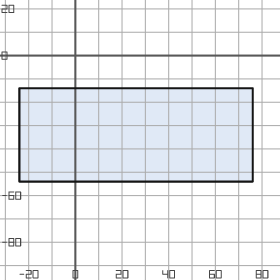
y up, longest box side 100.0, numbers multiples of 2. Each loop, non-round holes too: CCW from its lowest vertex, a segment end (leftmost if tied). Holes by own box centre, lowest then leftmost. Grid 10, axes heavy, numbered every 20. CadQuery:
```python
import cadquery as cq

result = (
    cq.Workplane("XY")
    .moveTo(-24.0, -54.0)
    .lineTo(76.0, -54.0)
    .lineTo(76.0, -14.0)
    .lineTo(-24.0, -14.0)
    .close()
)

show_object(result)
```